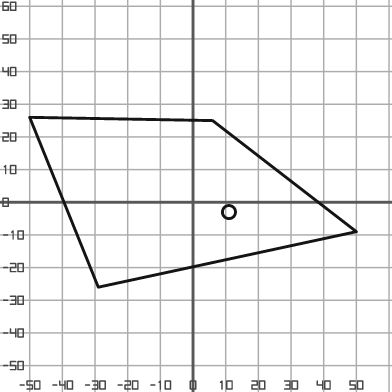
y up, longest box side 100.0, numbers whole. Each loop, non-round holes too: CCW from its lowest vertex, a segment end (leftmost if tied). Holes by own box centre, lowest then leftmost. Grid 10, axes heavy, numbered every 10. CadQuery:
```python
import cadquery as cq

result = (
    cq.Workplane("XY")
    .moveTo(-29.0, -26.0)
    .lineTo(50.0, -9.0)
    .lineTo(6.0, 25.0)
    .lineTo(-50.0, 26.0)
    .close()
    .moveTo(11.0, -3.0)
    .circle(2.0)
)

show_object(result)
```